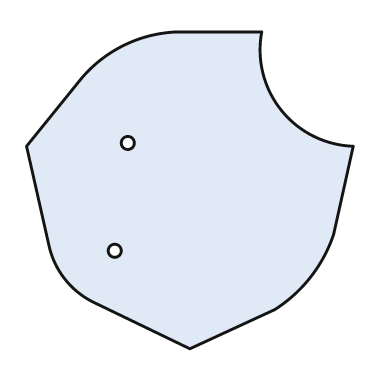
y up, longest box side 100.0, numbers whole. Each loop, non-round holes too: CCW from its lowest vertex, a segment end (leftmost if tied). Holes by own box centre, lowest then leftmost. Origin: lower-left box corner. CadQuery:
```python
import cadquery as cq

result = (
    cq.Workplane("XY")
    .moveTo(50.0, 0.0)
    .lineTo(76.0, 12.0)
    .threePointArc((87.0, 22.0), (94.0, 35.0))
    .lineTo(100.0, 62.0)
    .threePointArc((78.0, 73.0), (72.0, 97.0))
    .lineTo(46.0, 97.0)
    .threePointArc((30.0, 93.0), (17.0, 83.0))
    .lineTo(0.0, 62.0)
    .lineTo(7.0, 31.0)
    .threePointArc((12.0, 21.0), (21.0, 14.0))
    .close()
    .moveTo(27.0, 30.0)
    .circle(2.0)
    .moveTo(31.0, 63.0)
    .circle(2.0)
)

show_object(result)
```